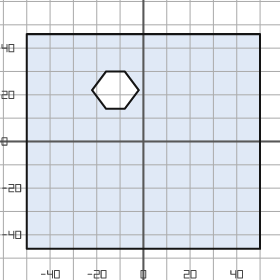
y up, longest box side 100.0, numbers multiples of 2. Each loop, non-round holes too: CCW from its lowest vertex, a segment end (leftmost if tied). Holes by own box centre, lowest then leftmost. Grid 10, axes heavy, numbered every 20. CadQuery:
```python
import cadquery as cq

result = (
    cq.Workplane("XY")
    .moveTo(-50.0, -46.0)
    .lineTo(50.0, -46.0)
    .lineTo(50.0, 46.0)
    .lineTo(-50.0, 46.0)
    .close()
    .moveTo(-16.0, 14.0)
    .lineTo(-8.0, 14.0)
    .lineTo(-2.0, 22.0)
    .lineTo(-8.0, 30.0)
    .lineTo(-16.0, 30.0)
    .lineTo(-22.0, 22.0)
    .close()
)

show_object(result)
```